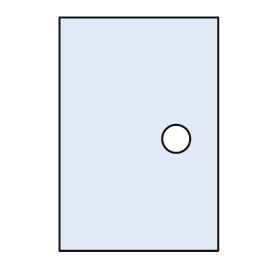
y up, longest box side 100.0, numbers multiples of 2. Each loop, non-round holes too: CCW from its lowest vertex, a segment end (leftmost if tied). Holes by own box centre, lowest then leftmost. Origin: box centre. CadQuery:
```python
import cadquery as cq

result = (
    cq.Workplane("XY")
    .moveTo(-34.0, -50.0)
    .lineTo(34.0, -50.0)
    .lineTo(34.0, 50.0)
    .lineTo(-34.0, 50.0)
    .close()
    .moveTo(16.0, -2.0)
    .circle(6.0)
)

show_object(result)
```